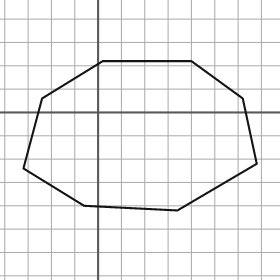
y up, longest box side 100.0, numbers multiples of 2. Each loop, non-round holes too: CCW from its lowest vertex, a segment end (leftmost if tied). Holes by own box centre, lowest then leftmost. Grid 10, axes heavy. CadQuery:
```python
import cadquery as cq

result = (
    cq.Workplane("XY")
    .moveTo(34.0, -42.0)
    .lineTo(68.0, -22.0)
    .lineTo(62.0, 6.0)
    .lineTo(40.0, 22.0)
    .lineTo(2.0, 22.0)
    .lineTo(-24.0, 6.0)
    .lineTo(-32.0, -24.0)
    .lineTo(-6.0, -40.0)
    .close()
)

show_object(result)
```